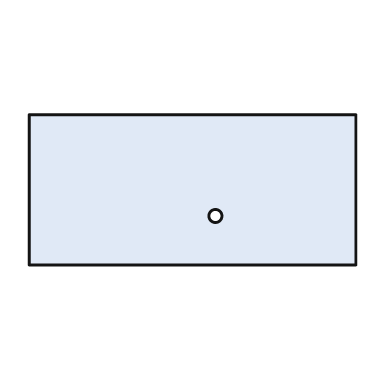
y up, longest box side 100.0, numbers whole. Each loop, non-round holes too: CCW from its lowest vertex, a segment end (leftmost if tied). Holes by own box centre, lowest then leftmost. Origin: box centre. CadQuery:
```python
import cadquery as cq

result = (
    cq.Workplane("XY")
    .moveTo(-50.0, -23.0)
    .lineTo(50.0, -23.0)
    .lineTo(50.0, 23.0)
    .lineTo(-50.0, 23.0)
    .close()
    .moveTo(7.0, -8.0)
    .circle(2.0)
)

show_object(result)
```